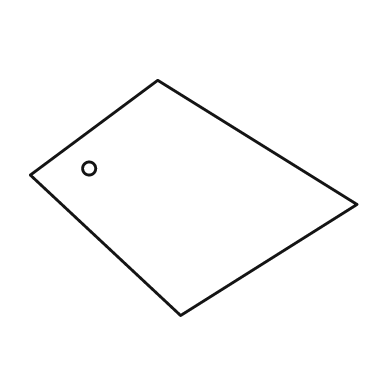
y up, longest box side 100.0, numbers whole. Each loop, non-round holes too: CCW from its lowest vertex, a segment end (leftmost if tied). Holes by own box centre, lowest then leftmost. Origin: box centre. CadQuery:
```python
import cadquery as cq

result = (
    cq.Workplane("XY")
    .moveTo(-4.0, -36.0)
    .lineTo(50.0, -2.0)
    .lineTo(-11.0, 36.0)
    .lineTo(-50.0, 7.0)
    .close()
    .moveTo(-32.0, 9.0)
    .circle(2.0)
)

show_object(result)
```